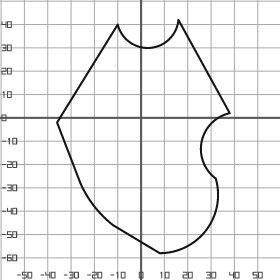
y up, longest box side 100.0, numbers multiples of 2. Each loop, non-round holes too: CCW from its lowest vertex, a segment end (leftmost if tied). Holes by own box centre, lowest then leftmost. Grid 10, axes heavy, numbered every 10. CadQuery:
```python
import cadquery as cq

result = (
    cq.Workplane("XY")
    .moveTo(8.0, -58.0)
    .threePointArc((28.0, -48.0), (32.0, -26.0))
    .threePointArc((26.0, -10.0), (38.0, 2.0))
    .lineTo(16.0, 42.0)
    .threePointArc((4.0, 30.0), (-10.0, 40.0))
    .lineTo(-36.0, -2.0)
    .lineTo(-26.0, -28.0)
    .threePointArc((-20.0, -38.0), (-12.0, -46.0))
    .close()
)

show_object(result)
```